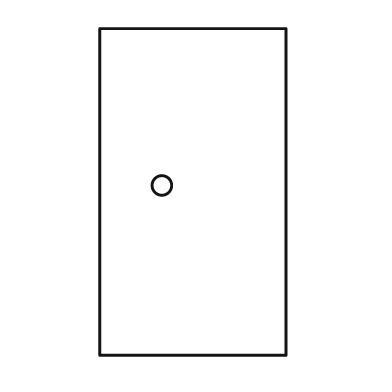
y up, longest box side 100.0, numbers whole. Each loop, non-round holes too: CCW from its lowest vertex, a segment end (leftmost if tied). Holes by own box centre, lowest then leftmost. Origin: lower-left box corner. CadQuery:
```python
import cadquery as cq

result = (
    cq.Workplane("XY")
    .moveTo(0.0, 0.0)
    .lineTo(57.0, 0.0)
    .lineTo(57.0, 100.0)
    .lineTo(0.0, 100.0)
    .close()
    .moveTo(19.0, 52.0)
    .circle(3.0)
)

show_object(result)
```